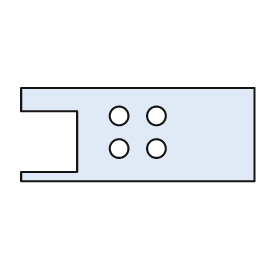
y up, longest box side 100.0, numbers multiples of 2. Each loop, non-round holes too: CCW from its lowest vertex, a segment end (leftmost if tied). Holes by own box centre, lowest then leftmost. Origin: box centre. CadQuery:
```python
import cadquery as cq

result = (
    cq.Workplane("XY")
    .moveTo(-50.0, -20.0)
    .lineTo(50.0, -20.0)
    .lineTo(50.0, 20.0)
    .lineTo(-50.0, 20.0)
    .lineTo(-50.0, 10.0)
    .lineTo(-26.0, 10.0)
    .lineTo(-26.0, -16.0)
    .lineTo(-50.0, -16.0)
    .close()
    .moveTo(-8.0, -6.0)
    .circle(4.0)
    .moveTo(8.0, -6.0)
    .circle(4.0)
    .moveTo(-8.0, 8.0)
    .circle(4.0)
    .moveTo(8.0, 8.0)
    .circle(4.0)
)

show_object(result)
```